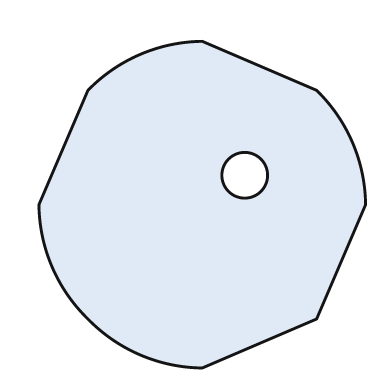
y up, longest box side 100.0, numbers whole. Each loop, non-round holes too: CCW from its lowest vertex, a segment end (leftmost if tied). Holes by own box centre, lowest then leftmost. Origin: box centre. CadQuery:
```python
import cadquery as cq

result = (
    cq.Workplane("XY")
    .moveTo(0.0, -50.0)
    .lineTo(35.0, -35.0)
    .lineTo(50.0, 0.0)
    .threePointArc((46.0, 19.0), (35.0, 35.0))
    .lineTo(0.0, 50.0)
    .threePointArc((-19.0, 46.0), (-35.0, 35.0))
    .lineTo(-50.0, 0.0)
    .threePointArc((-46.0, -19.0), (-35.0, -35.0))
    .threePointArc((-19.0, -46.0), (0.0, -50.0))
    .close()
    .moveTo(13.0, 9.0)
    .circle(7.0)
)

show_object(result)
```